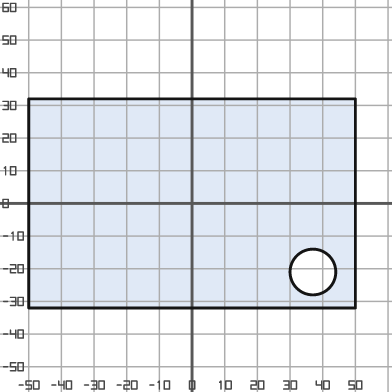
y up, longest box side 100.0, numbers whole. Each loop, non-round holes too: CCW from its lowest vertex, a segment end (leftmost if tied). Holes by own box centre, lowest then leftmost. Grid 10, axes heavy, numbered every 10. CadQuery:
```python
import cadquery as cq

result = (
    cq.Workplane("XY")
    .moveTo(-50.0, -32.0)
    .lineTo(50.0, -32.0)
    .lineTo(50.0, 32.0)
    .lineTo(-50.0, 32.0)
    .close()
    .moveTo(37.0, -21.0)
    .circle(7.0)
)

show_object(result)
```